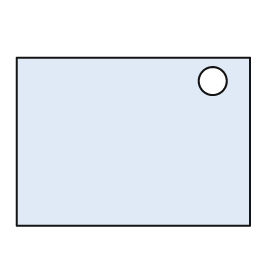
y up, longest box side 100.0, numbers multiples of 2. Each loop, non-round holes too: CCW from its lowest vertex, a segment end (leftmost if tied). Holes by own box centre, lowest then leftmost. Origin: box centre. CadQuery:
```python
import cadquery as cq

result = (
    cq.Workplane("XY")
    .moveTo(-50.0, -36.0)
    .lineTo(50.0, -36.0)
    .lineTo(50.0, 36.0)
    .lineTo(-50.0, 36.0)
    .close()
    .moveTo(34.0, 26.0)
    .circle(6.0)
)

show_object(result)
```